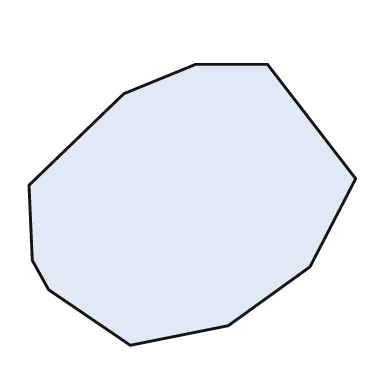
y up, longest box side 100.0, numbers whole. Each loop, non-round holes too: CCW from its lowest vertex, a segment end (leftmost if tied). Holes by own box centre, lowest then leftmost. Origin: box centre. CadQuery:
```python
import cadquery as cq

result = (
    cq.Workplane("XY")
    .moveTo(-19.0, -43.0)
    .lineTo(11.0, -37.0)
    .lineTo(36.0, -19.0)
    .lineTo(50.0, 8.0)
    .lineTo(23.0, 43.0)
    .lineTo(1.0, 43.0)
    .lineTo(-21.0, 34.0)
    .lineTo(-50.0, 6.0)
    .lineTo(-49.0, -17.0)
    .lineTo(-44.0, -26.0)
    .close()
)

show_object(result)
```